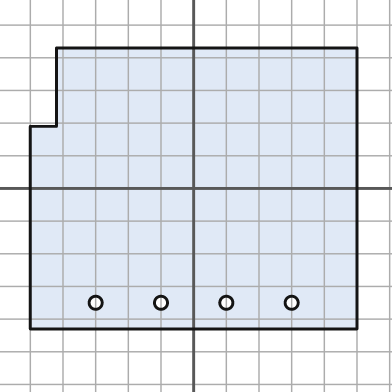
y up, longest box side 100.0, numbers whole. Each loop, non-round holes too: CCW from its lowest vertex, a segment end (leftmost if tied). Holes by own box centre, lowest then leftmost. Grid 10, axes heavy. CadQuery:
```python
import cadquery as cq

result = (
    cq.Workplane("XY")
    .moveTo(-50.0, -43.0)
    .lineTo(50.0, -43.0)
    .lineTo(50.0, 43.0)
    .lineTo(-42.0, 43.0)
    .lineTo(-42.0, 19.0)
    .lineTo(-50.0, 19.0)
    .close()
    .moveTo(-30.0, -35.0)
    .circle(2.0)
    .moveTo(-10.0, -35.0)
    .circle(2.0)
    .moveTo(10.0, -35.0)
    .circle(2.0)
    .moveTo(30.0, -35.0)
    .circle(2.0)
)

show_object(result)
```